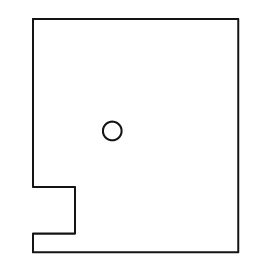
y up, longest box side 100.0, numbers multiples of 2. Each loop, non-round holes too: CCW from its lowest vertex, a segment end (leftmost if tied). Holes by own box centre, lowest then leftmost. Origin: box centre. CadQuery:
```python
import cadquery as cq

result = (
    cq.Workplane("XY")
    .moveTo(-44.0, -50.0)
    .lineTo(44.0, -50.0)
    .lineTo(44.0, 50.0)
    .lineTo(-44.0, 50.0)
    .lineTo(-44.0, -22.0)
    .lineTo(-26.0, -22.0)
    .lineTo(-26.0, -42.0)
    .lineTo(-44.0, -42.0)
    .close()
    .moveTo(-10.0, 2.0)
    .circle(4.0)
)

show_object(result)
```